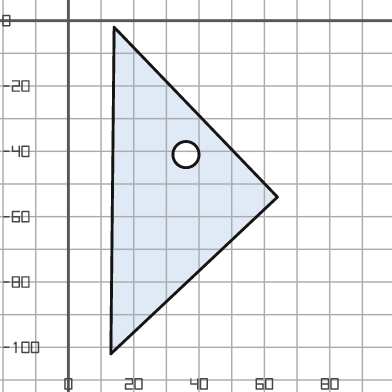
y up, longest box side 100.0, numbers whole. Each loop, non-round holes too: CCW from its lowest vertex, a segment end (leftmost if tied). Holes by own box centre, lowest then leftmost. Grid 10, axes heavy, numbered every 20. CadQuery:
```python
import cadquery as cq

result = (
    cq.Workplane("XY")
    .moveTo(13.0, -102.0)
    .lineTo(64.0, -54.0)
    .lineTo(14.0, -2.0)
    .close()
    .moveTo(36.0, -41.0)
    .circle(4.0)
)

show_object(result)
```